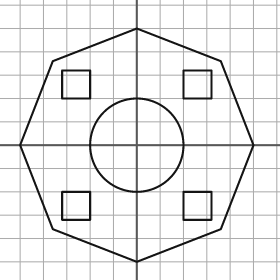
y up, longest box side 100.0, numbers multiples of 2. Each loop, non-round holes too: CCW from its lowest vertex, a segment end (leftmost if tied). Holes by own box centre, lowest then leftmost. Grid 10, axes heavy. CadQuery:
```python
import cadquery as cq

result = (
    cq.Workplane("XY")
    .moveTo(0.0, -50.0)
    .lineTo(36.0, -36.0)
    .lineTo(50.0, 0.0)
    .lineTo(36.0, 36.0)
    .lineTo(0.0, 50.0)
    .lineTo(-36.0, 36.0)
    .lineTo(-50.0, 0.0)
    .lineTo(-36.0, -36.0)
    .close()
    .moveTo(-32.0, -32.0)
    .lineTo(-20.0, -32.0)
    .lineTo(-20.0, -20.0)
    .lineTo(-32.0, -20.0)
    .close()
    .moveTo(20.0, -32.0)
    .lineTo(32.0, -32.0)
    .lineTo(32.0, -20.0)
    .lineTo(20.0, -20.0)
    .close()
    .moveTo(0.0, 0.0)
    .circle(20.0)
    .moveTo(-32.0, 20.0)
    .lineTo(-20.0, 20.0)
    .lineTo(-20.0, 32.0)
    .lineTo(-32.0, 32.0)
    .close()
    .moveTo(20.0, 20.0)
    .lineTo(32.0, 20.0)
    .lineTo(32.0, 32.0)
    .lineTo(20.0, 32.0)
    .close()
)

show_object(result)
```